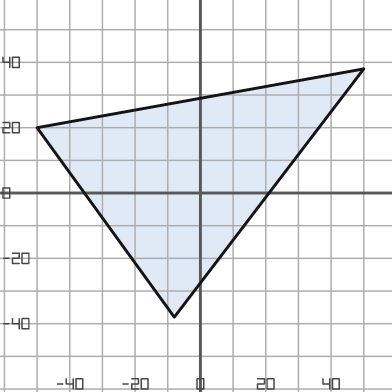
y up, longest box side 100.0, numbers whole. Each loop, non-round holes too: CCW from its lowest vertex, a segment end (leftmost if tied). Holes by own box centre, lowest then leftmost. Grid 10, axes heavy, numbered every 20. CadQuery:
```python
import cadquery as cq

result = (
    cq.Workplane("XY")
    .moveTo(-8.0, -38.0)
    .lineTo(50.0, 38.0)
    .lineTo(-50.0, 20.0)
    .close()
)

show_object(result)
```